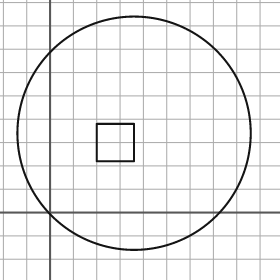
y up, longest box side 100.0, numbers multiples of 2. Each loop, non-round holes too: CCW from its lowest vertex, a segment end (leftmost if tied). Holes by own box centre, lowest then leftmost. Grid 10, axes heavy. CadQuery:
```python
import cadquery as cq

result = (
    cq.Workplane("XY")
    .moveTo(36.0, 34.0)
    .circle(50.0)
    .moveTo(20.0, 22.0)
    .lineTo(36.0, 22.0)
    .lineTo(36.0, 38.0)
    .lineTo(20.0, 38.0)
    .close()
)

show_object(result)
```